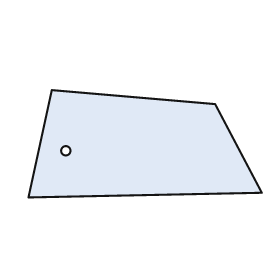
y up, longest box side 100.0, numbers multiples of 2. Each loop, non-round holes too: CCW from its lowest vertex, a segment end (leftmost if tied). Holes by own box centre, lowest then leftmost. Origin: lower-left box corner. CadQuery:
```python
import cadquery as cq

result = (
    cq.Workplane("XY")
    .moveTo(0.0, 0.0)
    .lineTo(100.0, 2.0)
    .lineTo(80.0, 40.0)
    .lineTo(10.0, 46.0)
    .close()
    .moveTo(16.0, 20.0)
    .circle(2.0)
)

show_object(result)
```